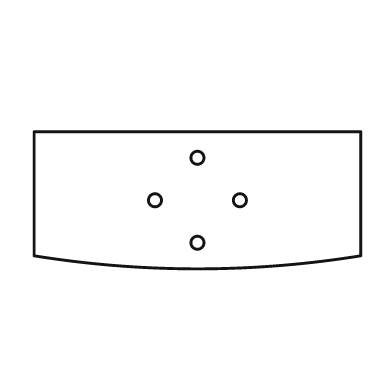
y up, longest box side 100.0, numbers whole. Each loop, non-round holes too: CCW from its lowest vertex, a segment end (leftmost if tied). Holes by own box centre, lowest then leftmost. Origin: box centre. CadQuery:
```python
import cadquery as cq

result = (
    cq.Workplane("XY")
    .moveTo(-50.0, -17.0)
    .threePointArc((0.0, -21.0), (50.0, -17.0))
    .lineTo(50.0, 21.0)
    .lineTo(-50.0, 21.0)
    .close()
    .moveTo(0.0, -13.0)
    .circle(2.0)
    .moveTo(-13.0, 0.0)
    .circle(2.0)
    .moveTo(13.0, 0.0)
    .circle(2.0)
    .moveTo(0.0, 13.0)
    .circle(2.0)
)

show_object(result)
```